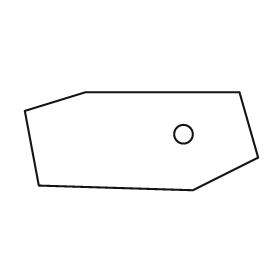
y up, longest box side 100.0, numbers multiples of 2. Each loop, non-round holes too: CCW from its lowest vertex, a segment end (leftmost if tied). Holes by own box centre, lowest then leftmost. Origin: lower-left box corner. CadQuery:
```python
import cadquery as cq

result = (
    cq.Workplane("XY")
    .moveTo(72.0, 0.0)
    .lineTo(100.0, 14.0)
    .lineTo(92.0, 42.0)
    .lineTo(26.0, 42.0)
    .lineTo(0.0, 34.0)
    .lineTo(6.0, 2.0)
    .close()
    .moveTo(68.0, 24.0)
    .circle(4.0)
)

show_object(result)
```